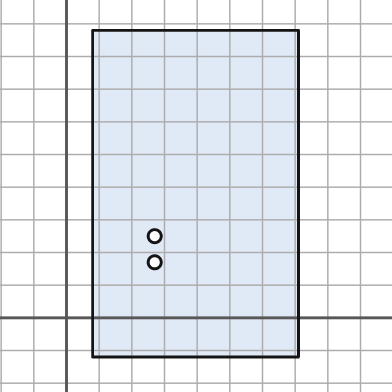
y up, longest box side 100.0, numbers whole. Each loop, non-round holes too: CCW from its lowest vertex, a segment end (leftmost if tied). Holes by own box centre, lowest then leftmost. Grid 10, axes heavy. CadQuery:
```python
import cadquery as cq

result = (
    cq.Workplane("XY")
    .moveTo(8.0, -12.0)
    .lineTo(71.0, -12.0)
    .lineTo(71.0, 88.0)
    .lineTo(8.0, 88.0)
    .close()
    .moveTo(27.0, 17.0)
    .circle(2.0)
    .moveTo(27.0, 25.0)
    .circle(2.0)
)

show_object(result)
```